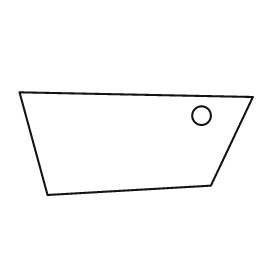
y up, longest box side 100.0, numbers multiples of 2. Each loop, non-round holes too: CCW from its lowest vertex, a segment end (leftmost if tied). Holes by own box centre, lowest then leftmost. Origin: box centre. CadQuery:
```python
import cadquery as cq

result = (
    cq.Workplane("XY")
    .moveTo(-38.0, -22.0)
    .lineTo(32.0, -18.0)
    .lineTo(50.0, 20.0)
    .lineTo(-50.0, 22.0)
    .close()
    .moveTo(28.0, 12.0)
    .circle(4.0)
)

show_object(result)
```